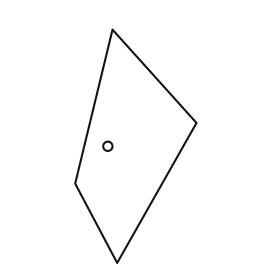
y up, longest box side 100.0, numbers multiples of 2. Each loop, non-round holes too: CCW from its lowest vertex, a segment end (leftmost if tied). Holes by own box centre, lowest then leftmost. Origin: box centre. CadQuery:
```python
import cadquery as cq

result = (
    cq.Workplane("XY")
    .moveTo(-8.0, -50.0)
    .lineTo(26.0, 10.0)
    .lineTo(-10.0, 50.0)
    .lineTo(-26.0, -16.0)
    .close()
    .moveTo(-12.0, 0.0)
    .circle(2.0)
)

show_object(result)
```